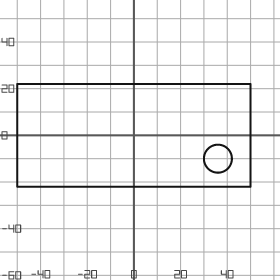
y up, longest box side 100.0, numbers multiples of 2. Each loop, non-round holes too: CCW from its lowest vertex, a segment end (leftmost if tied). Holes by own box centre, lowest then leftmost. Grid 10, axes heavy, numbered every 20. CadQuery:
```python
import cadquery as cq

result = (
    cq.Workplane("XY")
    .moveTo(-50.0, -22.0)
    .lineTo(50.0, -22.0)
    .lineTo(50.0, 22.0)
    .lineTo(-50.0, 22.0)
    .close()
    .moveTo(36.0, -10.0)
    .circle(6.0)
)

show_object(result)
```